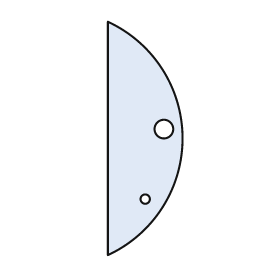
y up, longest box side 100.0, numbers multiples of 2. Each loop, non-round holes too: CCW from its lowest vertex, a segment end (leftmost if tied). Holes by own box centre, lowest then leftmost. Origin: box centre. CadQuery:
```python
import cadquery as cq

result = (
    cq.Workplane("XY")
    .moveTo(-16.0, -50.0)
    .threePointArc((16.0, 0.0), (-16.0, 50.0))
    .close()
    .moveTo(0.0, -26.0)
    .circle(2.0)
    .moveTo(8.0, 4.0)
    .circle(4.0)
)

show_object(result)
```